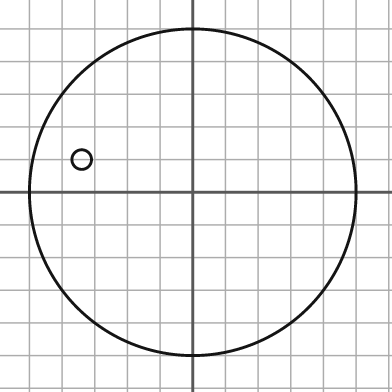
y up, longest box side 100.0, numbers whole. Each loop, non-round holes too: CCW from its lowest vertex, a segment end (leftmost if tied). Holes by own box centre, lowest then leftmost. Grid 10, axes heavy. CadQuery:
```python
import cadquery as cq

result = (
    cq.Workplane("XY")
    .moveTo(0.0, 0.0)
    .circle(50.0)
    .moveTo(-34.0, 10.0)
    .circle(3.0)
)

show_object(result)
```